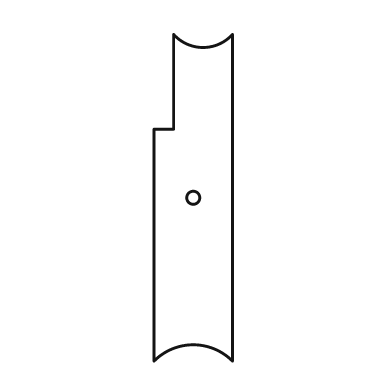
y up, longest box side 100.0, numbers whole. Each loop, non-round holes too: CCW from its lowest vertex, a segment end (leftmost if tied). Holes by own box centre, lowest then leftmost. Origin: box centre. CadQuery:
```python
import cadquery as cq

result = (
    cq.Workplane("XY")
    .moveTo(-12.0, -50.0)
    .threePointArc((0.0, -45.0), (12.0, -50.0))
    .lineTo(12.0, 50.0)
    .threePointArc((3.0, 46.0), (-6.0, 50.0))
    .lineTo(-6.0, 21.0)
    .lineTo(-12.0, 21.0)
    .close()
    .moveTo(0.0, 0.0)
    .circle(2.0)
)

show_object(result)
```